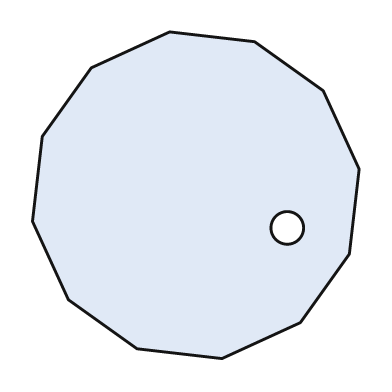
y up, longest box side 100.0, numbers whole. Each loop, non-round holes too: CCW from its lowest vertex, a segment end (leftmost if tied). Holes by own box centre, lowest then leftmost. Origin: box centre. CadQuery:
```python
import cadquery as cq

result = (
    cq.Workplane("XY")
    .moveTo(8.0, -50.0)
    .lineTo(32.0, -39.0)
    .lineTo(47.0, -18.0)
    .lineTo(50.0, 8.0)
    .lineTo(39.0, 32.0)
    .lineTo(18.0, 47.0)
    .lineTo(-8.0, 50.0)
    .lineTo(-32.0, 39.0)
    .lineTo(-47.0, 18.0)
    .lineTo(-50.0, -8.0)
    .lineTo(-39.0, -32.0)
    .lineTo(-18.0, -47.0)
    .close()
    .moveTo(28.0, -10.0)
    .circle(5.0)
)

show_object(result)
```